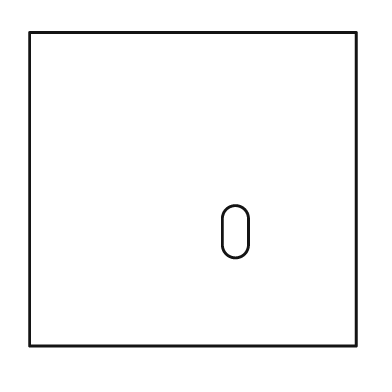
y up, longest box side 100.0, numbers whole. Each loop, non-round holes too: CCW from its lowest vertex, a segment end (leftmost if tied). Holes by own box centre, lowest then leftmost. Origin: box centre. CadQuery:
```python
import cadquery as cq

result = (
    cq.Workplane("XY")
    .moveTo(-50.0, -48.0)
    .lineTo(50.0, -48.0)
    .lineTo(50.0, 48.0)
    .lineTo(-50.0, 48.0)
    .close()
    .moveTo(9.0, -17.0)
    .threePointArc((13.0, -21.0), (17.0, -17.0))
    .lineTo(17.0, -9.0)
    .threePointArc((13.0, -5.0), (9.0, -9.0))
    .close()
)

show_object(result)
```